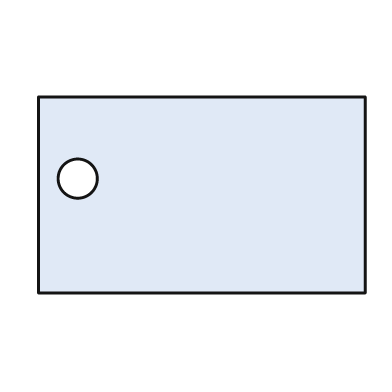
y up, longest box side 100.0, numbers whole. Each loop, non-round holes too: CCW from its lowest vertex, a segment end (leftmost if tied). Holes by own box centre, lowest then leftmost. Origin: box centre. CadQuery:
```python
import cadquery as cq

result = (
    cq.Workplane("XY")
    .moveTo(-50.0, -30.0)
    .lineTo(50.0, -30.0)
    .lineTo(50.0, 30.0)
    .lineTo(-50.0, 30.0)
    .close()
    .moveTo(-38.0, 5.0)
    .circle(6.0)
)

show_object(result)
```